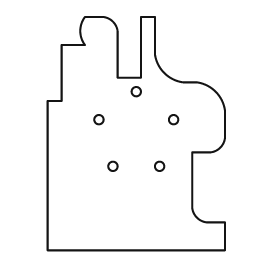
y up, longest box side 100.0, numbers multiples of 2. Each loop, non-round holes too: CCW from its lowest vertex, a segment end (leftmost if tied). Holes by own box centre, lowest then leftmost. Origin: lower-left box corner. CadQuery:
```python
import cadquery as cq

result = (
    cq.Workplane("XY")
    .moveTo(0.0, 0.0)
    .lineTo(76.0, 0.0)
    .lineTo(76.0, 12.0)
    .lineTo(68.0, 12.0)
    .threePointArc((64.0, 14.0), (62.0, 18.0))
    .lineTo(62.0, 42.0)
    .lineTo(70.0, 42.0)
    .threePointArc((74.0, 44.0), (76.0, 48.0))
    .lineTo(76.0, 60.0)
    .threePointArc((72.0, 68.0), (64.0, 72.0))
    .lineTo(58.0, 72.0)
    .threePointArc((50.0, 76.0), (46.0, 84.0))
    .lineTo(46.0, 100.0)
    .lineTo(40.0, 100.0)
    .lineTo(40.0, 74.0)
    .lineTo(30.0, 74.0)
    .lineTo(30.0, 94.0)
    .threePointArc((28.0, 98.0), (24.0, 100.0))
    .lineTo(16.0, 100.0)
    .threePointArc((14.0, 94.0), (16.0, 88.0))
    .lineTo(6.0, 88.0)
    .lineTo(6.0, 64.0)
    .lineTo(0.0, 64.0)
    .close()
    .moveTo(28.0, 36.0)
    .circle(2.0)
    .moveTo(48.0, 36.0)
    .circle(2.0)
    .moveTo(22.0, 56.0)
    .circle(2.0)
    .moveTo(54.0, 56.0)
    .circle(2.0)
    .moveTo(38.0, 68.0)
    .circle(2.0)
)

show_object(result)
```